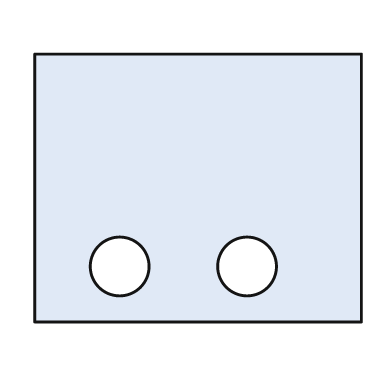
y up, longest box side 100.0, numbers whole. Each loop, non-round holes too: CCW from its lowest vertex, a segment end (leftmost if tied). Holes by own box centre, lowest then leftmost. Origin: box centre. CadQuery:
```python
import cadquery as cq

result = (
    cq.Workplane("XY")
    .moveTo(-50.0, -41.0)
    .lineTo(50.0, -41.0)
    .lineTo(50.0, 41.0)
    .lineTo(-50.0, 41.0)
    .close()
    .moveTo(-24.0, -24.0)
    .circle(9.0)
    .moveTo(15.0, -24.0)
    .circle(9.0)
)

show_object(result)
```